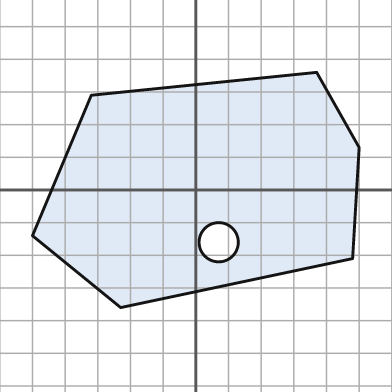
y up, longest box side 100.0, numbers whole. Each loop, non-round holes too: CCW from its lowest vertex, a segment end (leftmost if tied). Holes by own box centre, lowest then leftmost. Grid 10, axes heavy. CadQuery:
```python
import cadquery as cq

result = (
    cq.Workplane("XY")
    .moveTo(-23.0, -36.0)
    .lineTo(48.0, -21.0)
    .lineTo(50.0, 13.0)
    .lineTo(37.0, 36.0)
    .lineTo(-32.0, 29.0)
    .lineTo(-50.0, -14.0)
    .close()
    .moveTo(7.0, -16.0)
    .circle(6.0)
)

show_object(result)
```